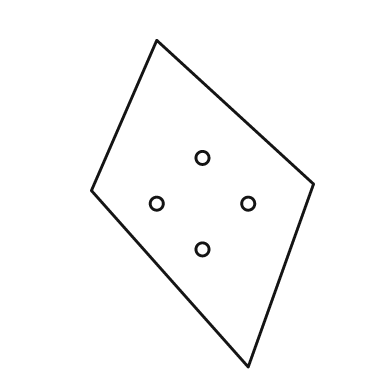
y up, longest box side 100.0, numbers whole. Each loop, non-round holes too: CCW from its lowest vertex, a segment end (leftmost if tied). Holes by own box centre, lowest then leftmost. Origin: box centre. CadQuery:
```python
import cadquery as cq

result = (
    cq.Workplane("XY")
    .moveTo(14.0, -50.0)
    .lineTo(34.0, 6.0)
    .lineTo(-14.0, 50.0)
    .lineTo(-34.0, 4.0)
    .close()
    .moveTo(0.0, -14.0)
    .circle(2.0)
    .moveTo(-14.0, 0.0)
    .circle(2.0)
    .moveTo(14.0, 0.0)
    .circle(2.0)
    .moveTo(0.0, 14.0)
    .circle(2.0)
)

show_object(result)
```